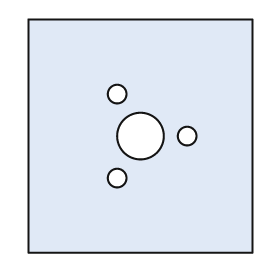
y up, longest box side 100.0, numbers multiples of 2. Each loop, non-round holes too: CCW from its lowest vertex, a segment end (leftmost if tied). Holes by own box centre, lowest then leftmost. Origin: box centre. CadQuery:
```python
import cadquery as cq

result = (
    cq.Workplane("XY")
    .moveTo(-48.0, -50.0)
    .lineTo(48.0, -50.0)
    .lineTo(48.0, 50.0)
    .lineTo(-48.0, 50.0)
    .close()
    .moveTo(-10.0, -18.0)
    .circle(4.0)
    .moveTo(0.0, 0.0)
    .circle(10.0)
    .moveTo(20.0, 0.0)
    .circle(4.0)
    .moveTo(-10.0, 18.0)
    .circle(4.0)
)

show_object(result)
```